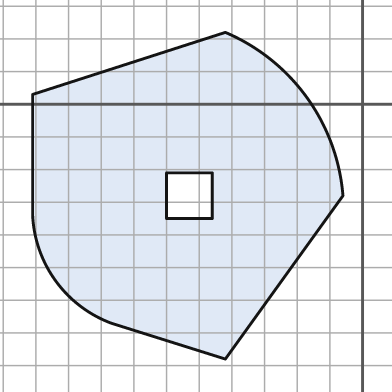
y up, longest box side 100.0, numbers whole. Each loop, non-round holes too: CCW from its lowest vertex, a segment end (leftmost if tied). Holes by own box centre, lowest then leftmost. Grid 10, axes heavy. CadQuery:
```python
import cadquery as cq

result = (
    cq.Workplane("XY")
    .moveTo(-42.0, -78.0)
    .lineTo(-6.0, -28.0)
    .threePointArc((-17.0, 2.0), (-42.0, 22.0))
    .lineTo(-101.0, 3.0)
    .lineTo(-101.0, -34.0)
    .threePointArc((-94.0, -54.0), (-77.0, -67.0))
    .close()
    .moveTo(-60.0, -35.0)
    .lineTo(-46.0, -35.0)
    .lineTo(-46.0, -21.0)
    .lineTo(-60.0, -21.0)
    .close()
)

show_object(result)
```